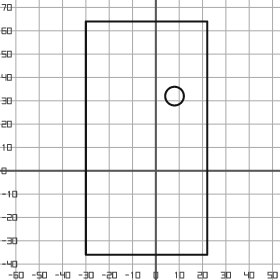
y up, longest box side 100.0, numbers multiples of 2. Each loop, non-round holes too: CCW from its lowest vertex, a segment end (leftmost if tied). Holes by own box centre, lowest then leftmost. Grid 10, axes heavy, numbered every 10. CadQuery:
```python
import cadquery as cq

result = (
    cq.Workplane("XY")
    .moveTo(-30.0, -36.0)
    .lineTo(22.0, -36.0)
    .lineTo(22.0, 64.0)
    .lineTo(-30.0, 64.0)
    .close()
    .moveTo(8.0, 32.0)
    .circle(4.0)
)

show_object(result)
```